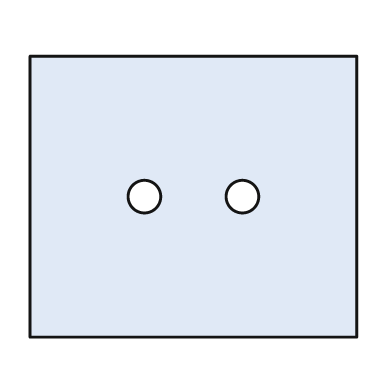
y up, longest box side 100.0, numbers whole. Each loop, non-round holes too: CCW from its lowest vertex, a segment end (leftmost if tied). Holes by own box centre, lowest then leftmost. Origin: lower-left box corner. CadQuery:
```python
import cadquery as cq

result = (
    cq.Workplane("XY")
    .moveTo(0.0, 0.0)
    .lineTo(100.0, 0.0)
    .lineTo(100.0, 86.0)
    .lineTo(0.0, 86.0)
    .close()
    .moveTo(35.0, 43.0)
    .circle(5.0)
    .moveTo(65.0, 43.0)
    .circle(5.0)
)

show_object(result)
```